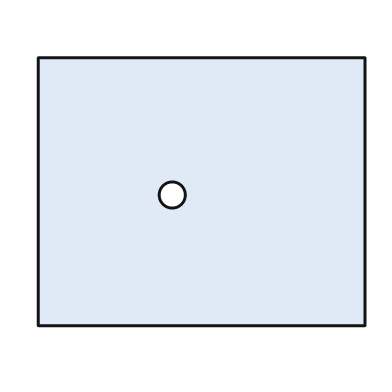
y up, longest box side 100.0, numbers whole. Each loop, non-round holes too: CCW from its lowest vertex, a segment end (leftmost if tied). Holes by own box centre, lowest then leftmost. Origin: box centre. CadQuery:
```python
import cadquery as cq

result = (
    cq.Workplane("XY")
    .moveTo(-50.0, -41.0)
    .lineTo(50.0, -41.0)
    .lineTo(50.0, 41.0)
    .lineTo(-50.0, 41.0)
    .close()
    .moveTo(-9.0, -1.0)
    .circle(4.0)
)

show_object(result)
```